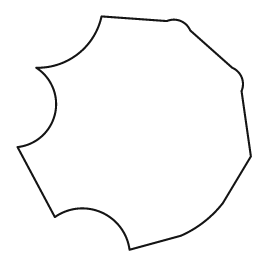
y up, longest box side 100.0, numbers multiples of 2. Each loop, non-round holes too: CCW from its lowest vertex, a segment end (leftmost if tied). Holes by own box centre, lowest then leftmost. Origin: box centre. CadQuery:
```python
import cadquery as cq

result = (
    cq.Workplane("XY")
    .moveTo(-2.0, -50.0)
    .lineTo(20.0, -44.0)
    .threePointArc((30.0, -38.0), (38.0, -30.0))
    .lineTo(50.0, -10.0)
    .lineTo(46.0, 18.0)
    .threePointArc((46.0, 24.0), (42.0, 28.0))
    .lineTo(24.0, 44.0)
    .threePointArc((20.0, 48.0), (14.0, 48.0))
    .lineTo(-14.0, 50.0)
    .threePointArc((-24.0, 34.0), (-42.0, 28.0))
    .threePointArc((-34.0, 8.0), (-50.0, -6.0))
    .lineTo(-34.0, -36.0)
    .threePointArc((-14.0, -34.0), (-2.0, -50.0))
    .close()
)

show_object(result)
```